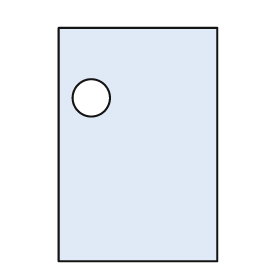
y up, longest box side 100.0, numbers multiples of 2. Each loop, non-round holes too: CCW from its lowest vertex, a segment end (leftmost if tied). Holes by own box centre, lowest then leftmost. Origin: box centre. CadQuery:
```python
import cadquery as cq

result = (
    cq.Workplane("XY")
    .moveTo(-34.0, -50.0)
    .lineTo(34.0, -50.0)
    .lineTo(34.0, 50.0)
    .lineTo(-34.0, 50.0)
    .close()
    .moveTo(-20.0, 20.0)
    .circle(8.0)
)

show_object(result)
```